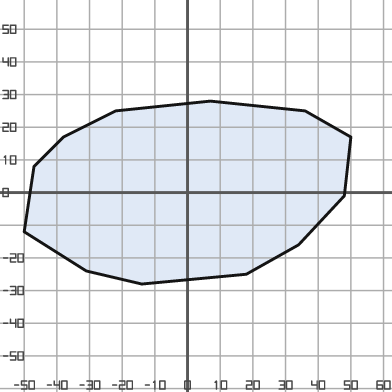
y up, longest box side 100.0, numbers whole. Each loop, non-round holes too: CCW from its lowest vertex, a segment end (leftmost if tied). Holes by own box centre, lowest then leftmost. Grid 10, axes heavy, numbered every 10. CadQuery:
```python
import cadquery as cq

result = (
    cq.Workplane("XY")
    .moveTo(-14.0, -28.0)
    .lineTo(18.0, -25.0)
    .lineTo(34.0, -16.0)
    .lineTo(48.0, -1.0)
    .lineTo(50.0, 17.0)
    .lineTo(36.0, 25.0)
    .lineTo(7.0, 28.0)
    .lineTo(-22.0, 25.0)
    .lineTo(-38.0, 17.0)
    .lineTo(-47.0, 8.0)
    .lineTo(-50.0, -12.0)
    .lineTo(-31.0, -24.0)
    .close()
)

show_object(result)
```